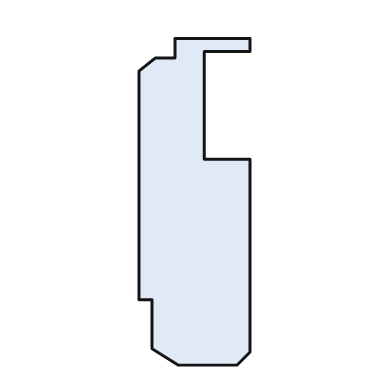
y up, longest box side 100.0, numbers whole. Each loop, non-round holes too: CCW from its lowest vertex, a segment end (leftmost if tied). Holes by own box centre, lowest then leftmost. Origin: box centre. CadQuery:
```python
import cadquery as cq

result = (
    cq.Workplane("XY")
    .moveTo(-5.0, -50.0)
    .lineTo(13.0, -50.0)
    .lineTo(17.0, -46.0)
    .lineTo(17.0, 13.0)
    .lineTo(3.0, 13.0)
    .lineTo(3.0, 46.0)
    .lineTo(17.0, 46.0)
    .lineTo(17.0, 50.0)
    .lineTo(-6.0, 50.0)
    .lineTo(-6.0, 44.0)
    .lineTo(-12.0, 44.0)
    .lineTo(-17.0, 40.0)
    .lineTo(-17.0, -30.0)
    .lineTo(-13.0, -30.0)
    .lineTo(-13.0, -45.0)
    .close()
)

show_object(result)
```